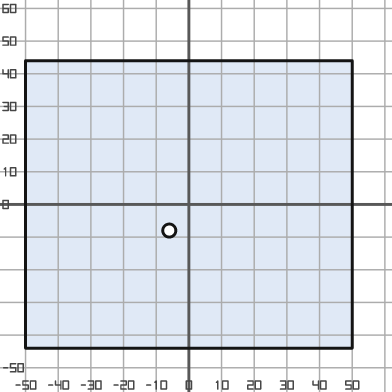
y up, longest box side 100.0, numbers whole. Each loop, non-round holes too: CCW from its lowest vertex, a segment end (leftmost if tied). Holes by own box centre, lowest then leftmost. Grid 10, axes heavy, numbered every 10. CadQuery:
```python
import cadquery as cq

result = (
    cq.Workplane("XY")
    .moveTo(-50.0, -44.0)
    .lineTo(50.0, -44.0)
    .lineTo(50.0, 44.0)
    .lineTo(-50.0, 44.0)
    .close()
    .moveTo(-6.0, -8.0)
    .circle(2.0)
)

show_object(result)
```